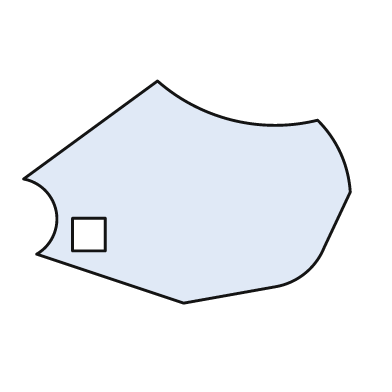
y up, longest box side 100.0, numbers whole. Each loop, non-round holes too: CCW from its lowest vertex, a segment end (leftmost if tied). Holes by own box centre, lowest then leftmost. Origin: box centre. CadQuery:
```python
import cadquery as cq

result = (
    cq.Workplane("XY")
    .moveTo(-1.0, -34.0)
    .lineTo(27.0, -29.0)
    .threePointArc((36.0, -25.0), (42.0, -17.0))
    .lineTo(50.0, 0.0)
    .threePointArc((47.0, 12.0), (40.0, 22.0))
    .threePointArc((14.0, 22.0), (-9.0, 34.0))
    .lineTo(-50.0, 4.0)
    .threePointArc((-40.0, -6.0), (-46.0, -19.0))
    .close()
    .moveTo(-35.0, -18.0)
    .lineTo(-25.0, -18.0)
    .lineTo(-25.0, -8.0)
    .lineTo(-35.0, -8.0)
    .close()
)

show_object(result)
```